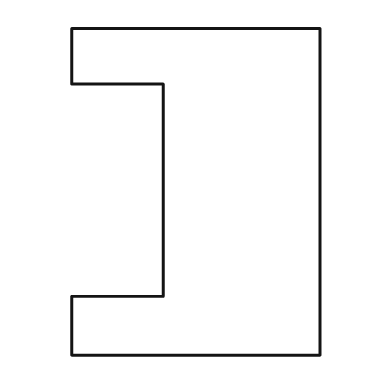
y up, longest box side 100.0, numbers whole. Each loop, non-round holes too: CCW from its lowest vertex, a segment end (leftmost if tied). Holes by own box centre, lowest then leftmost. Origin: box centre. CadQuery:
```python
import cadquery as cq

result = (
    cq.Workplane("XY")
    .moveTo(-38.0, -50.0)
    .lineTo(38.0, -50.0)
    .lineTo(38.0, 50.0)
    .lineTo(-38.0, 50.0)
    .lineTo(-38.0, 33.0)
    .lineTo(-10.0, 33.0)
    .lineTo(-10.0, -32.0)
    .lineTo(-38.0, -32.0)
    .close()
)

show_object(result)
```